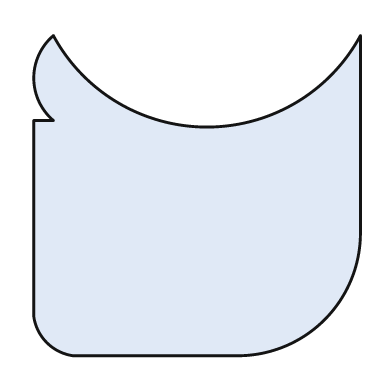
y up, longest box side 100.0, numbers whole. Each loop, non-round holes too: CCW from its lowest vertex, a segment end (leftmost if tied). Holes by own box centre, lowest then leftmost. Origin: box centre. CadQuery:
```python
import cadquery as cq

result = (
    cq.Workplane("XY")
    .moveTo(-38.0, -49.0)
    .lineTo(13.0, -49.0)
    .threePointArc((39.0, -38.0), (50.0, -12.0))
    .lineTo(50.0, 49.0)
    .threePointArc((3.0, 21.0), (-44.0, 49.0))
    .threePointArc((-50.0, 36.0), (-44.0, 23.0))
    .lineTo(-50.0, 23.0)
    .lineTo(-50.0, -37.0)
    .threePointArc((-46.0, -45.0), (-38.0, -49.0))
    .close()
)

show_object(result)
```